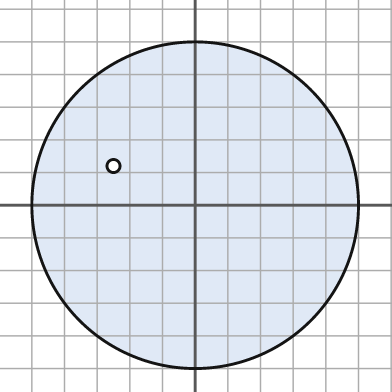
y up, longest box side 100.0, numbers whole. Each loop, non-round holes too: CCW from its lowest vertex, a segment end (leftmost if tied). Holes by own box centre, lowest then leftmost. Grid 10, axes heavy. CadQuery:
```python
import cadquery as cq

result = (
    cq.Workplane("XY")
    .moveTo(0.0, 0.0)
    .circle(50.0)
    .moveTo(-25.0, 12.0)
    .circle(2.0)
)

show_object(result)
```